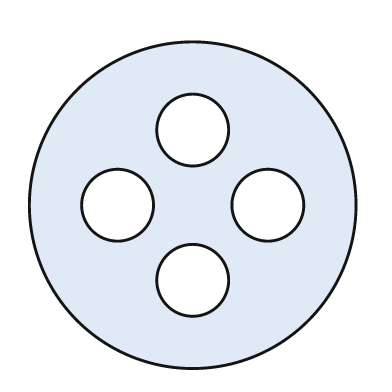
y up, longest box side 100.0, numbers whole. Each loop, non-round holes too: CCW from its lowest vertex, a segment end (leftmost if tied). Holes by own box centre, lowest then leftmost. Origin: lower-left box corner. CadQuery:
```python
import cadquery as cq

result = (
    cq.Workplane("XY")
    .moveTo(50.0, 50.0)
    .circle(50.0)
    .moveTo(50.0, 27.0)
    .circle(11.0)
    .moveTo(27.0, 50.0)
    .circle(11.0)
    .moveTo(73.0, 50.0)
    .circle(11.0)
    .moveTo(50.0, 73.0)
    .circle(11.0)
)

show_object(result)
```